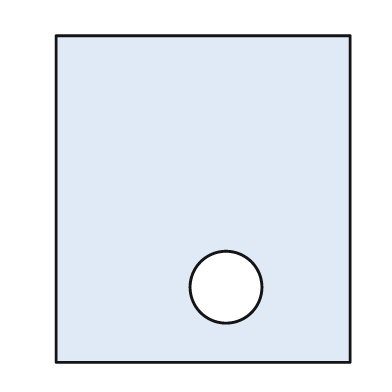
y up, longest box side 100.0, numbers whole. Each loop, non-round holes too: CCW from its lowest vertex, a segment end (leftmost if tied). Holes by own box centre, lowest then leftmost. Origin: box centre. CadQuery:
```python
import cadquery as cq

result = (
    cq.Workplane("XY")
    .moveTo(-45.0, -50.0)
    .lineTo(45.0, -50.0)
    .lineTo(45.0, 50.0)
    .lineTo(-45.0, 50.0)
    .close()
    .moveTo(7.0, -27.0)
    .circle(11.0)
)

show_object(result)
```